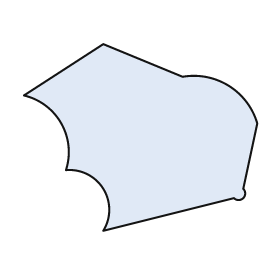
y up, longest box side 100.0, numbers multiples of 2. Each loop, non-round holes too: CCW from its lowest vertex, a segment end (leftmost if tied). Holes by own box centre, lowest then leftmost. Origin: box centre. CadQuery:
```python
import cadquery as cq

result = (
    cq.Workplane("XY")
    .moveTo(-16.0, -40.0)
    .lineTo(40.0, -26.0)
    .threePointArc((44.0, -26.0), (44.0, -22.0))
    .lineTo(50.0, 6.0)
    .threePointArc((38.0, 22.0), (18.0, 26.0))
    .lineTo(-16.0, 40.0)
    .lineTo(-50.0, 18.0)
    .threePointArc((-34.0, 6.0), (-32.0, -14.0))
    .threePointArc((-16.0, -22.0), (-16.0, -40.0))
    .close()
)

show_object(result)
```